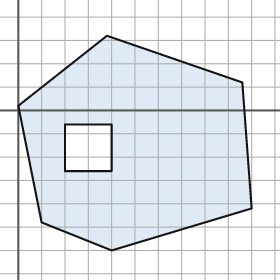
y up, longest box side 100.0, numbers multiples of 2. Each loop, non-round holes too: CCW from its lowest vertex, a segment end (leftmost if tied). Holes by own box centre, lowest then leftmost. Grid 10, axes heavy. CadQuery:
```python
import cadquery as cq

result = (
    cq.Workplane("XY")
    .moveTo(40.0, -60.0)
    .lineTo(100.0, -42.0)
    .lineTo(96.0, 12.0)
    .lineTo(38.0, 32.0)
    .lineTo(0.0, 2.0)
    .lineTo(10.0, -48.0)
    .close()
    .moveTo(20.0, -26.0)
    .lineTo(40.0, -26.0)
    .lineTo(40.0, -6.0)
    .lineTo(20.0, -6.0)
    .close()
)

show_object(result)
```